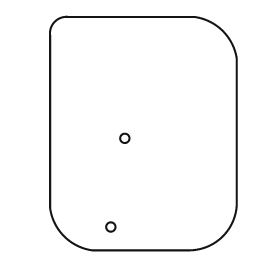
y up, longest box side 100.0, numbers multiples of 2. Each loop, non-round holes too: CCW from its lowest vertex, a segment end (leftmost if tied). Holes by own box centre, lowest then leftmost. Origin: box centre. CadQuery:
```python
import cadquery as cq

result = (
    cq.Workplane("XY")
    .moveTo(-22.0, -50.0)
    .lineTo(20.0, -50.0)
    .threePointArc((34.0, -44.0), (40.0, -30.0))
    .lineTo(40.0, 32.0)
    .threePointArc((34.0, 44.0), (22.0, 50.0))
    .lineTo(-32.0, 50.0)
    .threePointArc((-38.0, 48.0), (-40.0, 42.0))
    .lineTo(-40.0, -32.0)
    .threePointArc((-34.0, -44.0), (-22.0, -50.0))
    .close()
    .moveTo(-14.0, -40.0)
    .circle(2.0)
    .moveTo(-8.0, -2.0)
    .circle(2.0)
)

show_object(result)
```